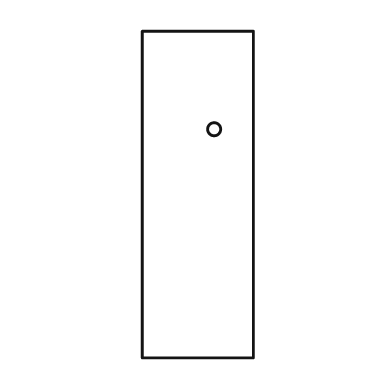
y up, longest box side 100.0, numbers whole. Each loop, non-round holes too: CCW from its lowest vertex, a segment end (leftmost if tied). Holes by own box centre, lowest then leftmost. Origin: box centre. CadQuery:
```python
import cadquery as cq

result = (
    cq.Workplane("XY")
    .moveTo(-17.0, -50.0)
    .lineTo(17.0, -50.0)
    .lineTo(17.0, 50.0)
    .lineTo(-17.0, 50.0)
    .close()
    .moveTo(5.0, 20.0)
    .circle(2.0)
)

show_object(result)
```